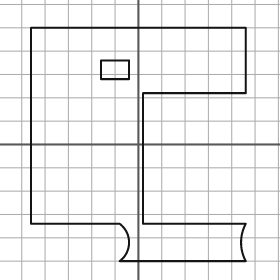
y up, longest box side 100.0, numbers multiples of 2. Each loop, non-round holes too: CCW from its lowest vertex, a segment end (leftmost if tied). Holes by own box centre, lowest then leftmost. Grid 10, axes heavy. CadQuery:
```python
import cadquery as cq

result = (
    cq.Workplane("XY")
    .moveTo(-8.0, -50.0)
    .lineTo(46.0, -50.0)
    .threePointArc((44.0, -42.0), (46.0, -34.0))
    .lineTo(2.0, -34.0)
    .lineTo(2.0, 22.0)
    .lineTo(46.0, 22.0)
    .lineTo(46.0, 50.0)
    .lineTo(-46.0, 50.0)
    .lineTo(-46.0, -34.0)
    .lineTo(-8.0, -34.0)
    .threePointArc((-4.0, -42.0), (-8.0, -50.0))
    .close()
    .moveTo(-16.0, 28.0)
    .lineTo(-4.0, 28.0)
    .lineTo(-4.0, 36.0)
    .lineTo(-16.0, 36.0)
    .close()
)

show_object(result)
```